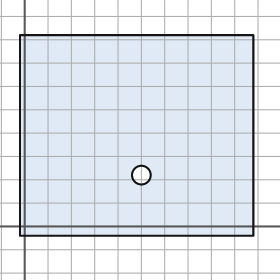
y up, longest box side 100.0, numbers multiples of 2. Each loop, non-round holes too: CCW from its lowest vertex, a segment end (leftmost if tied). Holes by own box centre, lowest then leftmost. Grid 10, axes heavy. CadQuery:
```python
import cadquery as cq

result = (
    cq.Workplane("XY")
    .moveTo(-2.0, -4.0)
    .lineTo(98.0, -4.0)
    .lineTo(98.0, 82.0)
    .lineTo(-2.0, 82.0)
    .close()
    .moveTo(50.0, 22.0)
    .circle(4.0)
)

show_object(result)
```